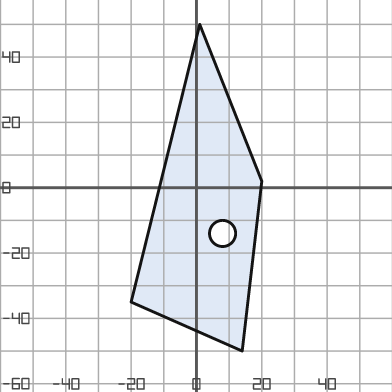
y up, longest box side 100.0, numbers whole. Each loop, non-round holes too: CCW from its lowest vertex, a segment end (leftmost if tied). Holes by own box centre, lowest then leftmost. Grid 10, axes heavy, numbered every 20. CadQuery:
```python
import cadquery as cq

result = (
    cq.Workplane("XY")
    .moveTo(14.0, -50.0)
    .lineTo(20.0, 2.0)
    .lineTo(1.0, 50.0)
    .lineTo(-20.0, -35.0)
    .close()
    .moveTo(8.0, -14.0)
    .circle(4.0)
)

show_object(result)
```